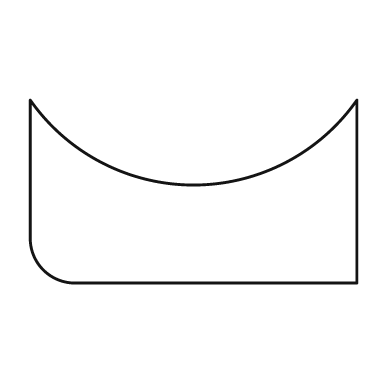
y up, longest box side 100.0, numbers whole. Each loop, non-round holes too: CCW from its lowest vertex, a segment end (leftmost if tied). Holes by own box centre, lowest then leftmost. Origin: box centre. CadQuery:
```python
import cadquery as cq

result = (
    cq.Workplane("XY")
    .moveTo(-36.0, -28.0)
    .lineTo(50.0, -28.0)
    .lineTo(50.0, 28.0)
    .threePointArc((0.0, 2.0), (-50.0, 28.0))
    .lineTo(-50.0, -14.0)
    .threePointArc((-46.0, -24.0), (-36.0, -28.0))
    .close()
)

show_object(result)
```